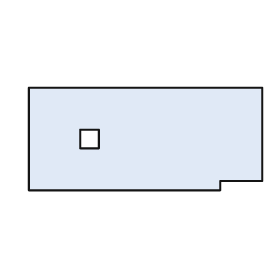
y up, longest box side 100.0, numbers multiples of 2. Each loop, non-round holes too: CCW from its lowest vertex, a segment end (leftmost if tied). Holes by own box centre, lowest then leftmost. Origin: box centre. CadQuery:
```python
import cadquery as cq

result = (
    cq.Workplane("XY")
    .moveTo(-50.0, -22.0)
    .lineTo(32.0, -22.0)
    .lineTo(32.0, -18.0)
    .lineTo(50.0, -18.0)
    .lineTo(50.0, 22.0)
    .lineTo(-50.0, 22.0)
    .close()
    .moveTo(-28.0, -4.0)
    .lineTo(-20.0, -4.0)
    .lineTo(-20.0, 4.0)
    .lineTo(-28.0, 4.0)
    .close()
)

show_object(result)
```